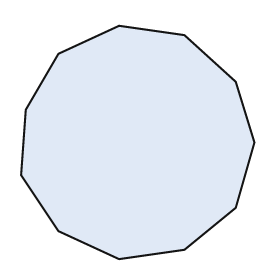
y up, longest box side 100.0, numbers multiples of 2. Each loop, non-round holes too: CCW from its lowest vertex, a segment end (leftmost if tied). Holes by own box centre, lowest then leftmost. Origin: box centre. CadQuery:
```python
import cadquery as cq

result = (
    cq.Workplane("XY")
    .moveTo(-8.0, -50.0)
    .lineTo(20.0, -46.0)
    .lineTo(42.0, -28.0)
    .lineTo(50.0, 0.0)
    .lineTo(42.0, 26.0)
    .lineTo(20.0, 46.0)
    .lineTo(-8.0, 50.0)
    .lineTo(-34.0, 38.0)
    .lineTo(-48.0, 14.0)
    .lineTo(-50.0, -14.0)
    .lineTo(-34.0, -38.0)
    .close()
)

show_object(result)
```